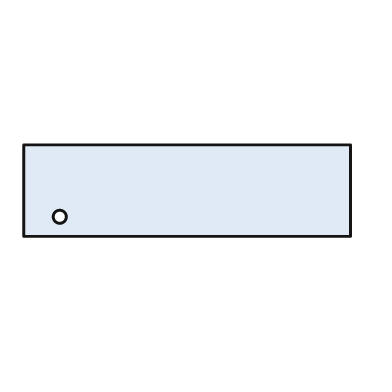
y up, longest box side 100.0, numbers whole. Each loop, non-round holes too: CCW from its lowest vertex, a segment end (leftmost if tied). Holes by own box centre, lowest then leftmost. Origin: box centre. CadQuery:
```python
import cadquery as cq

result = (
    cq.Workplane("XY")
    .moveTo(-50.0, -14.0)
    .lineTo(50.0, -14.0)
    .lineTo(50.0, 14.0)
    .lineTo(-50.0, 14.0)
    .close()
    .moveTo(-39.0, -8.0)
    .circle(2.0)
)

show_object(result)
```